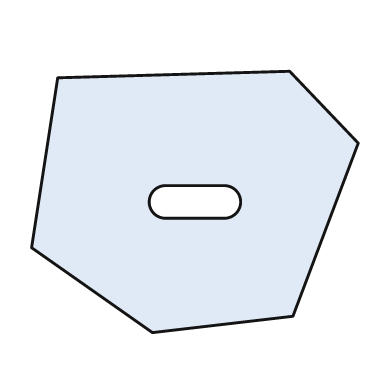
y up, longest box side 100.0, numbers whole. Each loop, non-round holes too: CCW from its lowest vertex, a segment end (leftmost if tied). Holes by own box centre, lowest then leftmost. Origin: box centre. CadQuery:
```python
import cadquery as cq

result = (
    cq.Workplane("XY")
    .moveTo(-13.0, -40.0)
    .lineTo(30.0, -35.0)
    .lineTo(50.0, 18.0)
    .lineTo(29.0, 40.0)
    .lineTo(-42.0, 38.0)
    .lineTo(-50.0, -14.0)
    .close()
    .moveTo(-9.0, -5.0)
    .lineTo(9.0, -5.0)
    .threePointArc((14.0, 0.0), (9.0, 5.0))
    .lineTo(-9.0, 5.0)
    .threePointArc((-14.0, 0.0), (-9.0, -5.0))
    .close()
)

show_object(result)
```